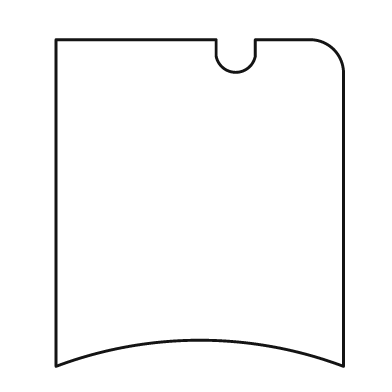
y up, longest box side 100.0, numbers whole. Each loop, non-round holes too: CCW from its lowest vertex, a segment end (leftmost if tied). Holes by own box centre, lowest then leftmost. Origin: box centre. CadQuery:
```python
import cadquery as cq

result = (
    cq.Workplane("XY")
    .moveTo(-44.0, -50.0)
    .threePointArc((0.0, -42.0), (44.0, -50.0))
    .lineTo(44.0, 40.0)
    .threePointArc((41.0, 47.0), (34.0, 50.0))
    .lineTo(17.0, 50.0)
    .lineTo(17.0, 45.0)
    .threePointArc((11.0, 40.0), (5.0, 45.0))
    .lineTo(5.0, 50.0)
    .lineTo(-44.0, 50.0)
    .close()
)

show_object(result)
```